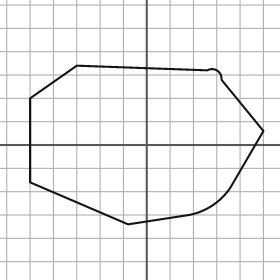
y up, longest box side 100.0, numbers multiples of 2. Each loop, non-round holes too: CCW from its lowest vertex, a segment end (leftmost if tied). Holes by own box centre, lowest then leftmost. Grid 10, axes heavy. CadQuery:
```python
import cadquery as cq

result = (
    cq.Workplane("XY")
    .moveTo(-8.0, -34.0)
    .lineTo(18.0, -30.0)
    .threePointArc((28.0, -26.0), (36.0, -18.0))
    .lineTo(50.0, 6.0)
    .lineTo(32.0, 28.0)
    .threePointArc((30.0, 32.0), (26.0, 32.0))
    .lineTo(-30.0, 34.0)
    .lineTo(-50.0, 20.0)
    .lineTo(-50.0, -16.0)
    .close()
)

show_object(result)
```